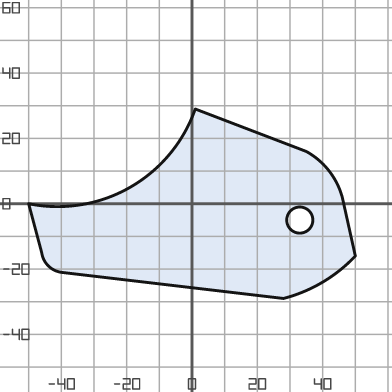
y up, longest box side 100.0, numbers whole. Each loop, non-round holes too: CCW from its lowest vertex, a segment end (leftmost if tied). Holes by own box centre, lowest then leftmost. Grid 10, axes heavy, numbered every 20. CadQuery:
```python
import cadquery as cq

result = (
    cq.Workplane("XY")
    .moveTo(28.0, -29.0)
    .threePointArc((40.0, -24.0), (50.0, -16.0))
    .lineTo(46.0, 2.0)
    .threePointArc((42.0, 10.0), (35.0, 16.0))
    .lineTo(1.0, 29.0)
    .threePointArc((-19.0, 5.0), (-50.0, 0.0))
    .lineTo(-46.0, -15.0)
    .threePointArc((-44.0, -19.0), (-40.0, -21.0))
    .close()
    .moveTo(33.0, -5.0)
    .circle(4.0)
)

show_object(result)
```